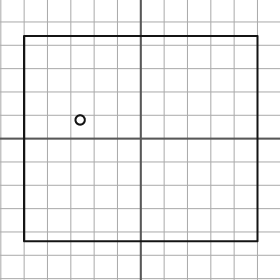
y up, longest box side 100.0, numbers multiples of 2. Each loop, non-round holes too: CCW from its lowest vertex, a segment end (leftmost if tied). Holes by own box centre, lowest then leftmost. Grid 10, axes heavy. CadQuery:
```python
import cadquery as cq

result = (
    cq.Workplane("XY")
    .moveTo(-50.0, -44.0)
    .lineTo(50.0, -44.0)
    .lineTo(50.0, 44.0)
    .lineTo(-50.0, 44.0)
    .close()
    .moveTo(-26.0, 8.0)
    .circle(2.0)
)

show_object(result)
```